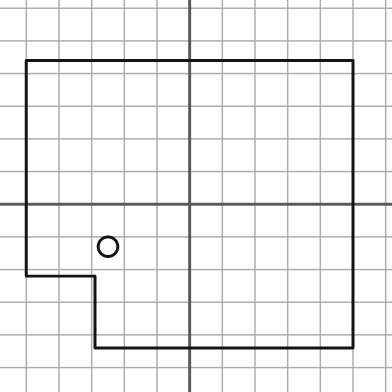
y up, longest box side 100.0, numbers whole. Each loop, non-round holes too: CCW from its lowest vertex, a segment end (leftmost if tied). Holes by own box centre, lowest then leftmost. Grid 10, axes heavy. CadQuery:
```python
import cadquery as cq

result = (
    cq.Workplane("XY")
    .moveTo(-29.0, -44.0)
    .lineTo(50.0, -44.0)
    .lineTo(50.0, 44.0)
    .lineTo(-50.0, 44.0)
    .lineTo(-50.0, -22.0)
    .lineTo(-29.0, -22.0)
    .close()
    .moveTo(-25.0, -13.0)
    .circle(3.0)
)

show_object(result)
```